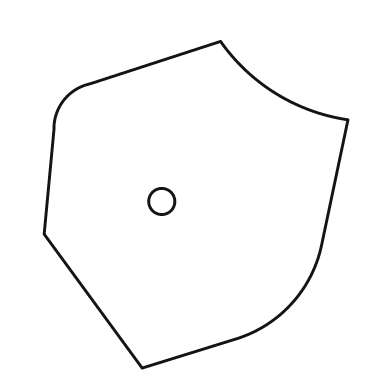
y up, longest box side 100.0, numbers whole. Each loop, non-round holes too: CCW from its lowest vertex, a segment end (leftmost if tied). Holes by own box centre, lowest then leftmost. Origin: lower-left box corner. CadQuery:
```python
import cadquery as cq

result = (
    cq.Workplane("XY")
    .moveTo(30.0, 0.0)
    .lineTo(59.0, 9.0)
    .threePointArc((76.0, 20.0), (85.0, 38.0))
    .lineTo(93.0, 76.0)
    .threePointArc((71.0, 84.0), (54.0, 100.0))
    .lineTo(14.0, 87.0)
    .threePointArc((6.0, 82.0), (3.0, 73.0))
    .lineTo(0.0, 41.0)
    .close()
    .moveTo(36.0, 51.0)
    .circle(4.0)
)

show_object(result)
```